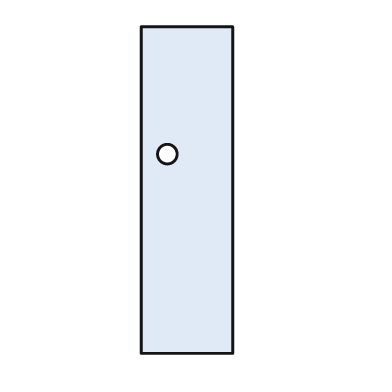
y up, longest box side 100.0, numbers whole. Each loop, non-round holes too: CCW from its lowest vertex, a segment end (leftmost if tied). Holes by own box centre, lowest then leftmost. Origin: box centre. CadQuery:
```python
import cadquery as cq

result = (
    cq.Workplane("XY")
    .moveTo(-14.0, -50.0)
    .lineTo(14.0, -50.0)
    .lineTo(14.0, 50.0)
    .lineTo(-14.0, 50.0)
    .close()
    .moveTo(-6.0, 11.0)
    .circle(3.0)
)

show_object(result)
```